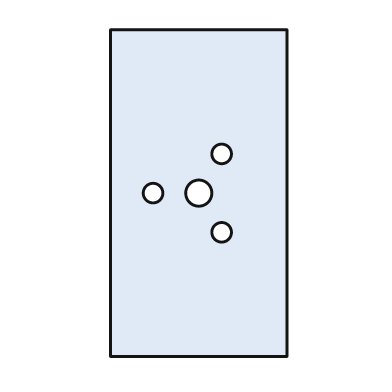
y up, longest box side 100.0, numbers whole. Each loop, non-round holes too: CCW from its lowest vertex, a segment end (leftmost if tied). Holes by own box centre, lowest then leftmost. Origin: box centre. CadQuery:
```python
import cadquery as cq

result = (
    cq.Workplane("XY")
    .moveTo(-27.0, -50.0)
    .lineTo(27.0, -50.0)
    .lineTo(27.0, 50.0)
    .lineTo(-27.0, 50.0)
    .close()
    .moveTo(7.0, -12.0)
    .circle(3.0)
    .moveTo(-14.0, 0.0)
    .circle(3.0)
    .moveTo(0.0, 0.0)
    .circle(4.0)
    .moveTo(7.0, 12.0)
    .circle(3.0)
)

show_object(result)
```